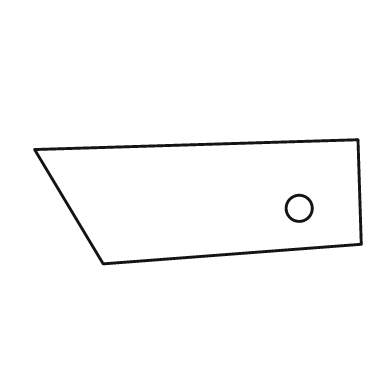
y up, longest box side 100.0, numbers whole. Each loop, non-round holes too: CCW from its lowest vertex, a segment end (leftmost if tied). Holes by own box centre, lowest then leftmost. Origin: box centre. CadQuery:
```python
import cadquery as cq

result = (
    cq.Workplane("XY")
    .moveTo(-29.0, -19.0)
    .lineTo(50.0, -13.0)
    .lineTo(49.0, 19.0)
    .lineTo(-50.0, 16.0)
    .close()
    .moveTo(31.0, -2.0)
    .circle(4.0)
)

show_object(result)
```